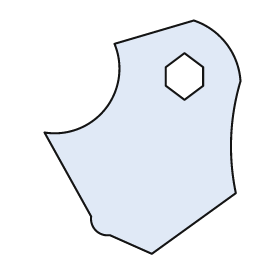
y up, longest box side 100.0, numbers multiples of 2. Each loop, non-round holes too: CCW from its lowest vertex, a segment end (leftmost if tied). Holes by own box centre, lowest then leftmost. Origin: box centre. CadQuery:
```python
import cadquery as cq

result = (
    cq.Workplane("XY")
    .moveTo(4.0, -50.0)
    .lineTo(40.0, -24.0)
    .threePointArc((38.0, 0.0), (42.0, 24.0))
    .threePointArc((36.0, 40.0), (22.0, 50.0))
    .lineTo(-12.0, 40.0)
    .threePointArc((-16.0, 12.0), (-42.0, 2.0))
    .lineTo(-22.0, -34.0)
    .threePointArc((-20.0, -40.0), (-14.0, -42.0))
    .close()
    .moveTo(18.0, 16.0)
    .lineTo(26.0, 22.0)
    .lineTo(26.0, 30.0)
    .lineTo(18.0, 36.0)
    .lineTo(10.0, 30.0)
    .lineTo(10.0, 22.0)
    .close()
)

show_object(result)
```